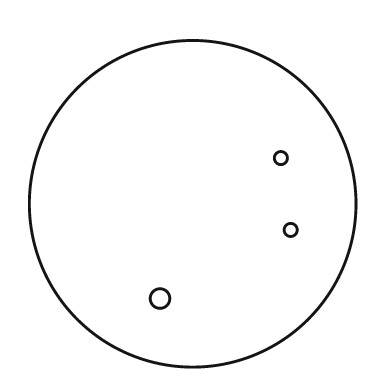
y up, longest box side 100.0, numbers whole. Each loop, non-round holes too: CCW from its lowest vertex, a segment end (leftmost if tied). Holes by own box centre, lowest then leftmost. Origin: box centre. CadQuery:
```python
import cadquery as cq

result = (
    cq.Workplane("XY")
    .moveTo(0.0, 0.0)
    .circle(50.0)
    .moveTo(-10.0, -29.0)
    .circle(3.0)
    .moveTo(30.0, -8.0)
    .circle(2.0)
    .moveTo(27.0, 14.0)
    .circle(2.0)
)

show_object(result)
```